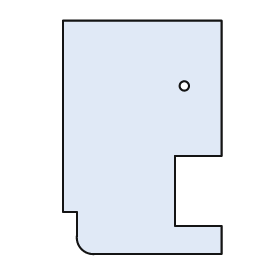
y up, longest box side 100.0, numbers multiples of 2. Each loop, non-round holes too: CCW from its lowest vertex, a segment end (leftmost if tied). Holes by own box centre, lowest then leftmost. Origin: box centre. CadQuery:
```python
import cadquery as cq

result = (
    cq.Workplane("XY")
    .moveTo(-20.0, -50.0)
    .lineTo(34.0, -50.0)
    .lineTo(34.0, -38.0)
    .lineTo(14.0, -38.0)
    .lineTo(14.0, -8.0)
    .lineTo(34.0, -8.0)
    .lineTo(34.0, 50.0)
    .lineTo(-34.0, 50.0)
    .lineTo(-34.0, -32.0)
    .lineTo(-28.0, -32.0)
    .lineTo(-28.0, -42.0)
    .threePointArc((-26.0, -48.0), (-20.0, -50.0))
    .close()
    .moveTo(18.0, 22.0)
    .circle(2.0)
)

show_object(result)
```